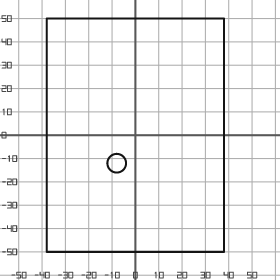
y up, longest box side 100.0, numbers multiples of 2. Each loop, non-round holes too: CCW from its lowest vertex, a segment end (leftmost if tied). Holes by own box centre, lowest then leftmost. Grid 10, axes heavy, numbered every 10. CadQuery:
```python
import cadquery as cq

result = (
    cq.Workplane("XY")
    .moveTo(-38.0, -50.0)
    .lineTo(38.0, -50.0)
    .lineTo(38.0, 50.0)
    .lineTo(-38.0, 50.0)
    .close()
    .moveTo(-8.0, -12.0)
    .circle(4.0)
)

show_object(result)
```